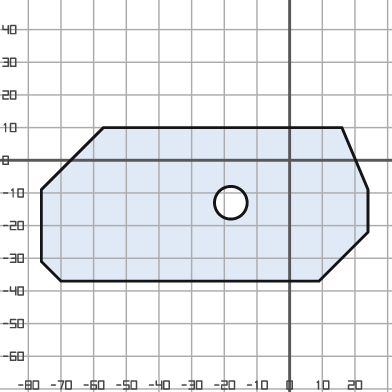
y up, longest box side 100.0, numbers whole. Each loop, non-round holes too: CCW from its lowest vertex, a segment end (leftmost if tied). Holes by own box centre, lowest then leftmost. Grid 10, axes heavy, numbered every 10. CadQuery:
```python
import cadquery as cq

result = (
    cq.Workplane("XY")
    .moveTo(-70.0, -37.0)
    .lineTo(9.0, -37.0)
    .lineTo(24.0, -22.0)
    .lineTo(24.0, -9.0)
    .lineTo(16.0, 10.0)
    .lineTo(-57.0, 10.0)
    .lineTo(-76.0, -9.0)
    .lineTo(-76.0, -31.0)
    .close()
    .moveTo(-18.0, -13.0)
    .circle(5.0)
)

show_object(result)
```